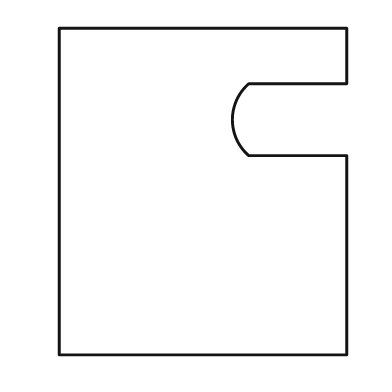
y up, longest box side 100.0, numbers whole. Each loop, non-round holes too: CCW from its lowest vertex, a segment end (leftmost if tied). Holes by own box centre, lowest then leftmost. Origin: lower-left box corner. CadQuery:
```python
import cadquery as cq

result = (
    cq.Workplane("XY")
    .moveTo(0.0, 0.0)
    .lineTo(88.0, 0.0)
    .lineTo(88.0, 61.0)
    .lineTo(58.0, 61.0)
    .threePointArc((53.0, 72.0), (58.0, 83.0))
    .lineTo(88.0, 83.0)
    .lineTo(88.0, 100.0)
    .lineTo(0.0, 100.0)
    .close()
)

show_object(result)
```